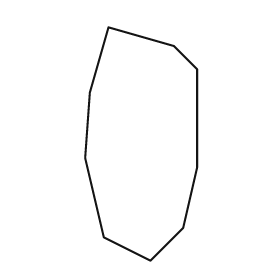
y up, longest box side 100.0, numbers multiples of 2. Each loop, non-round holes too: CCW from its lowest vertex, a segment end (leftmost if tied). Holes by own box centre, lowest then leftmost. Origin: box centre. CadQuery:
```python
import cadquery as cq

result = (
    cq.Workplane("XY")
    .moveTo(4.0, -50.0)
    .lineTo(18.0, -36.0)
    .lineTo(24.0, -10.0)
    .lineTo(24.0, 32.0)
    .lineTo(14.0, 42.0)
    .lineTo(-14.0, 50.0)
    .lineTo(-22.0, 22.0)
    .lineTo(-24.0, -6.0)
    .lineTo(-16.0, -40.0)
    .close()
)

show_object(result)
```